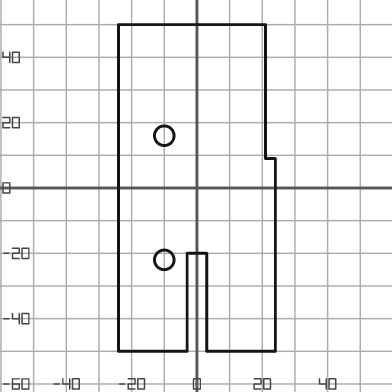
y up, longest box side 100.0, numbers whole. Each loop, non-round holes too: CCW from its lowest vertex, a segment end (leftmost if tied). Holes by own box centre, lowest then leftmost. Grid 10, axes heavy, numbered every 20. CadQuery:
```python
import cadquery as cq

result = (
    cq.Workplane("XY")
    .moveTo(-24.0, -50.0)
    .lineTo(-3.0, -50.0)
    .lineTo(-3.0, -20.0)
    .lineTo(3.0, -20.0)
    .lineTo(3.0, -50.0)
    .lineTo(24.0, -50.0)
    .lineTo(24.0, 9.0)
    .lineTo(21.0, 9.0)
    .lineTo(21.0, 50.0)
    .lineTo(-24.0, 50.0)
    .close()
    .moveTo(-10.0, -22.0)
    .circle(3.0)
    .moveTo(-10.0, 16.0)
    .circle(3.0)
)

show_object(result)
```